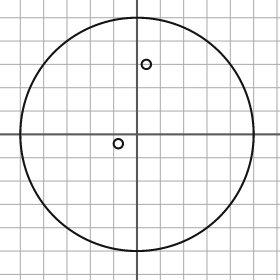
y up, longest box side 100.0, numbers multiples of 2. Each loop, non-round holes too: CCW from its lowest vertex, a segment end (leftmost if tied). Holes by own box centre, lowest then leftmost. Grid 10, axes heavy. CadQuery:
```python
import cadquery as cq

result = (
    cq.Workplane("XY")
    .moveTo(0.0, 0.0)
    .circle(50.0)
    .moveTo(-8.0, -4.0)
    .circle(2.0)
    .moveTo(4.0, 30.0)
    .circle(2.0)
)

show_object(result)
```